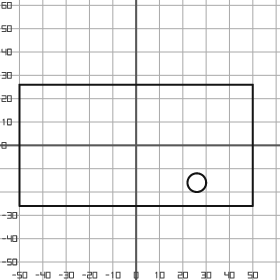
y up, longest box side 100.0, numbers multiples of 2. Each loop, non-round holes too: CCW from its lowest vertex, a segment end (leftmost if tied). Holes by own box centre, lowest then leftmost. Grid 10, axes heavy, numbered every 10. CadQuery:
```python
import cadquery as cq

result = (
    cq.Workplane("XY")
    .moveTo(-50.0, -26.0)
    .lineTo(50.0, -26.0)
    .lineTo(50.0, 26.0)
    .lineTo(-50.0, 26.0)
    .close()
    .moveTo(26.0, -16.0)
    .circle(4.0)
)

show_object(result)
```